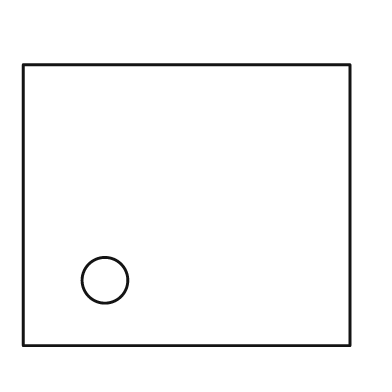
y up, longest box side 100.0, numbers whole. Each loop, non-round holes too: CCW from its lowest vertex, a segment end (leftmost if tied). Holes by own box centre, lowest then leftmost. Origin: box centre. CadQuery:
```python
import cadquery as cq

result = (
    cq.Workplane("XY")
    .moveTo(-50.0, -43.0)
    .lineTo(50.0, -43.0)
    .lineTo(50.0, 43.0)
    .lineTo(-50.0, 43.0)
    .close()
    .moveTo(-25.0, -23.0)
    .circle(7.0)
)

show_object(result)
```